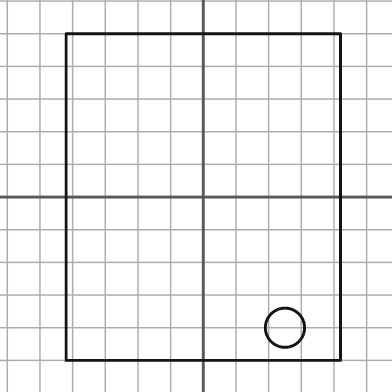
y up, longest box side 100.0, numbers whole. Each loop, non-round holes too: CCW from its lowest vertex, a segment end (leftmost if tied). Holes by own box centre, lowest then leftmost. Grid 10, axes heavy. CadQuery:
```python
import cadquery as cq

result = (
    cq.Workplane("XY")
    .moveTo(-42.0, -50.0)
    .lineTo(42.0, -50.0)
    .lineTo(42.0, 50.0)
    .lineTo(-42.0, 50.0)
    .close()
    .moveTo(25.0, -40.0)
    .circle(6.0)
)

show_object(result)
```